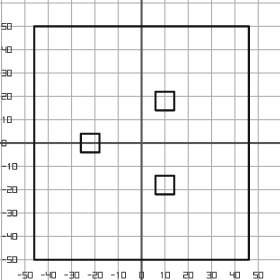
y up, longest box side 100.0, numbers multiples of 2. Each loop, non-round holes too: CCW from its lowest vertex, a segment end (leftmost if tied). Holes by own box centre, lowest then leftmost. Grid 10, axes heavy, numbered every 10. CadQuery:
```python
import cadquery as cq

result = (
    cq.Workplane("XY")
    .moveTo(-46.0, -50.0)
    .lineTo(46.0, -50.0)
    .lineTo(46.0, 50.0)
    .lineTo(-46.0, 50.0)
    .close()
    .moveTo(6.0, -22.0)
    .lineTo(14.0, -22.0)
    .lineTo(14.0, -14.0)
    .lineTo(6.0, -14.0)
    .close()
    .moveTo(-26.0, -4.0)
    .lineTo(-18.0, -4.0)
    .lineTo(-18.0, 4.0)
    .lineTo(-26.0, 4.0)
    .close()
    .moveTo(6.0, 14.0)
    .lineTo(14.0, 14.0)
    .lineTo(14.0, 22.0)
    .lineTo(6.0, 22.0)
    .close()
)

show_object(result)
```